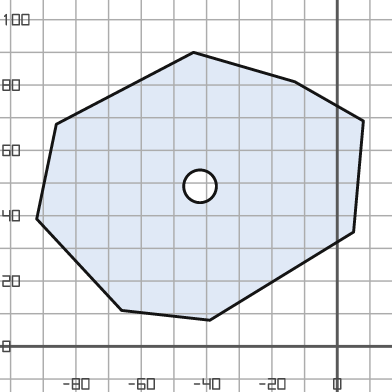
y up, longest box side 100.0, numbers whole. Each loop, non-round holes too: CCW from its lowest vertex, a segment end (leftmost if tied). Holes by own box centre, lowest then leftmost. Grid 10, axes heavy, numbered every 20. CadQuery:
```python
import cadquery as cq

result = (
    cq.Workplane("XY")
    .moveTo(-39.0, 8.0)
    .lineTo(5.0, 35.0)
    .lineTo(8.0, 69.0)
    .lineTo(-13.0, 81.0)
    .lineTo(-44.0, 90.0)
    .lineTo(-86.0, 68.0)
    .lineTo(-92.0, 39.0)
    .lineTo(-66.0, 11.0)
    .close()
    .moveTo(-42.0, 49.0)
    .circle(5.0)
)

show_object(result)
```